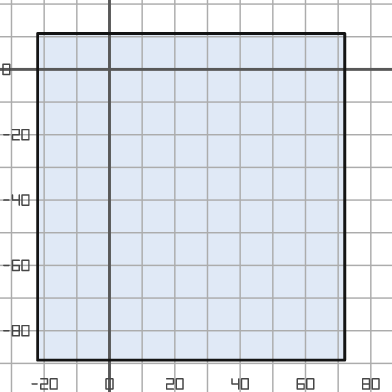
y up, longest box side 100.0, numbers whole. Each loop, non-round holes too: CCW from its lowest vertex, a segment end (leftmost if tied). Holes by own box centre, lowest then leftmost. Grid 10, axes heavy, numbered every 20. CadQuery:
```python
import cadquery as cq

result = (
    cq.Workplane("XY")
    .moveTo(-22.0, -89.0)
    .lineTo(72.0, -89.0)
    .lineTo(72.0, 11.0)
    .lineTo(-22.0, 11.0)
    .close()
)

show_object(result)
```